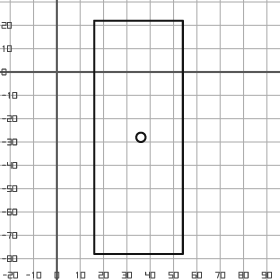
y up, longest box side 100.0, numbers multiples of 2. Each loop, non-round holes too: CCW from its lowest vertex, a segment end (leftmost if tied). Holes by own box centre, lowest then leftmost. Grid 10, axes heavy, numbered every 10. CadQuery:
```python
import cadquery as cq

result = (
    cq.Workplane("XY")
    .moveTo(16.0, -78.0)
    .lineTo(54.0, -78.0)
    .lineTo(54.0, 22.0)
    .lineTo(16.0, 22.0)
    .close()
    .moveTo(36.0, -28.0)
    .circle(2.0)
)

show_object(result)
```